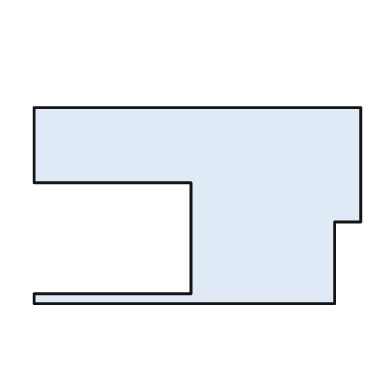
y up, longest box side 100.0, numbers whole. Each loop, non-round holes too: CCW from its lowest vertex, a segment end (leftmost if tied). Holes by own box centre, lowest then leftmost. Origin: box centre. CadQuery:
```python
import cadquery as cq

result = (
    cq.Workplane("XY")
    .moveTo(-50.0, -30.0)
    .lineTo(42.0, -30.0)
    .lineTo(42.0, -5.0)
    .lineTo(50.0, -5.0)
    .lineTo(50.0, 30.0)
    .lineTo(-50.0, 30.0)
    .lineTo(-50.0, 7.0)
    .lineTo(-2.0, 7.0)
    .lineTo(-2.0, -27.0)
    .lineTo(-50.0, -27.0)
    .close()
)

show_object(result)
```